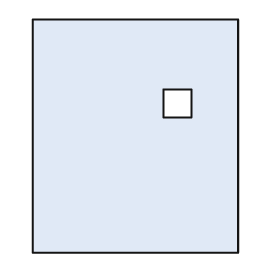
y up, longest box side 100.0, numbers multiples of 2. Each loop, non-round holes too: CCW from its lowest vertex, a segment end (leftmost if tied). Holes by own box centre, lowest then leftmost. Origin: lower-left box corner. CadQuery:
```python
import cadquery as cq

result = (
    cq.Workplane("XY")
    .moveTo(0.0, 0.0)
    .lineTo(88.0, 0.0)
    .lineTo(88.0, 100.0)
    .lineTo(0.0, 100.0)
    .close()
    .moveTo(56.0, 58.0)
    .lineTo(68.0, 58.0)
    .lineTo(68.0, 70.0)
    .lineTo(56.0, 70.0)
    .close()
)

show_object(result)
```